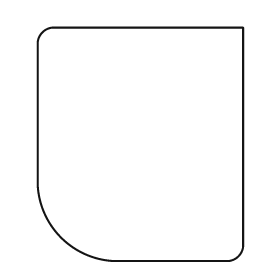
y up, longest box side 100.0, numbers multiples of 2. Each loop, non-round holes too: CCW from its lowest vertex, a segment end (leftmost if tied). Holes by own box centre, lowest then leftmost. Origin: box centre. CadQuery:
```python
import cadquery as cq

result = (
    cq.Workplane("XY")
    .moveTo(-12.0, -50.0)
    .lineTo(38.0, -50.0)
    .threePointArc((42.0, -48.0), (44.0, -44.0))
    .lineTo(44.0, 50.0)
    .lineTo(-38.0, 50.0)
    .threePointArc((-42.0, 48.0), (-44.0, 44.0))
    .lineTo(-44.0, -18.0)
    .threePointArc((-34.0, -40.0), (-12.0, -50.0))
    .close()
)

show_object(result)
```